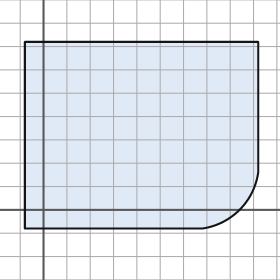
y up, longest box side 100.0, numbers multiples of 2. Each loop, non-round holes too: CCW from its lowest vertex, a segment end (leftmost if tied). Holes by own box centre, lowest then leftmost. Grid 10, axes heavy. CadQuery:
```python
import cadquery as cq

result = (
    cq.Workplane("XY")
    .moveTo(-8.0, -8.0)
    .lineTo(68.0, -8.0)
    .threePointArc((84.0, 0.0), (92.0, 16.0))
    .lineTo(92.0, 72.0)
    .lineTo(-8.0, 72.0)
    .close()
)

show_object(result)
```